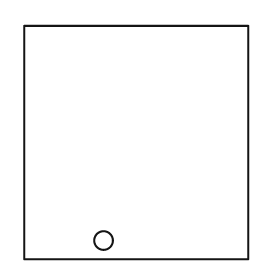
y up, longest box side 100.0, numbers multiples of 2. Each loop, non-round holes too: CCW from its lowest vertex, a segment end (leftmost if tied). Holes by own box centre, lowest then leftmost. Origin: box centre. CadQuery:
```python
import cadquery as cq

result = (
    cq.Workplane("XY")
    .moveTo(-48.0, -50.0)
    .lineTo(48.0, -50.0)
    .lineTo(48.0, 50.0)
    .lineTo(-48.0, 50.0)
    .close()
    .moveTo(-14.0, -42.0)
    .circle(4.0)
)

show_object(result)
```